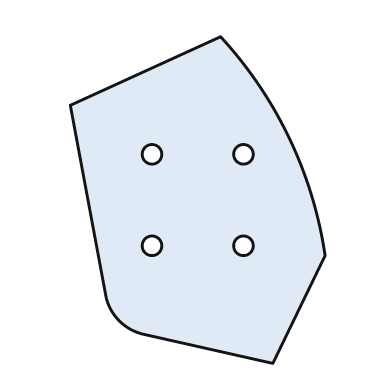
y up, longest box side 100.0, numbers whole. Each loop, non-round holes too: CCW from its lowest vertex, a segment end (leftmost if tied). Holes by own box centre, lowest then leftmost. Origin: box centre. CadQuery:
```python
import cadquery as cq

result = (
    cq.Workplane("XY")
    .moveTo(23.0, -50.0)
    .lineTo(39.0, -17.0)
    .threePointArc((28.0, 19.0), (7.0, 50.0))
    .lineTo(-39.0, 29.0)
    .lineTo(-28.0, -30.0)
    .threePointArc((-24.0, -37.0), (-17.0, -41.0))
    .close()
    .moveTo(-14.0, -14.0)
    .circle(3.0)
    .moveTo(14.0, -14.0)
    .circle(3.0)
    .moveTo(-14.0, 14.0)
    .circle(3.0)
    .moveTo(14.0, 14.0)
    .circle(3.0)
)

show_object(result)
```